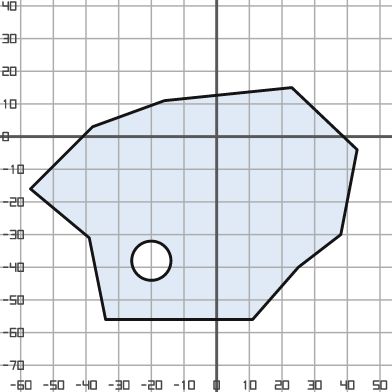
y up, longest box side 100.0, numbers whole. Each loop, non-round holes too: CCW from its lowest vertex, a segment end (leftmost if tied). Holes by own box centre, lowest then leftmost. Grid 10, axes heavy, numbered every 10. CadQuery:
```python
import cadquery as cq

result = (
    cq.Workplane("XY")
    .moveTo(-34.0, -56.0)
    .lineTo(11.0, -56.0)
    .lineTo(25.0, -40.0)
    .lineTo(38.0, -30.0)
    .lineTo(43.0, -4.0)
    .lineTo(23.0, 15.0)
    .lineTo(-16.0, 11.0)
    .lineTo(-38.0, 3.0)
    .lineTo(-57.0, -16.0)
    .lineTo(-39.0, -31.0)
    .close()
    .moveTo(-20.0, -38.0)
    .circle(6.0)
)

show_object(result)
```